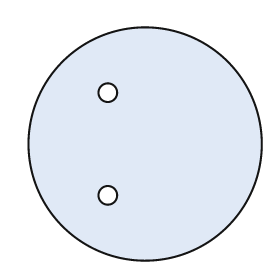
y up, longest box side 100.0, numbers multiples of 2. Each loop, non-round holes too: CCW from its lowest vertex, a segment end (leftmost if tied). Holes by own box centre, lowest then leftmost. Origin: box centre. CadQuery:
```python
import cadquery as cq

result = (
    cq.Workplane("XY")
    .moveTo(0.0, 0.0)
    .circle(50.0)
    .moveTo(-16.0, -22.0)
    .circle(4.0)
    .moveTo(-16.0, 22.0)
    .circle(4.0)
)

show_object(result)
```